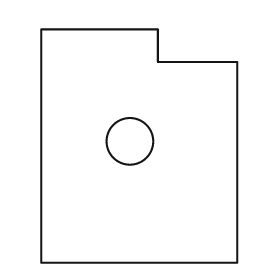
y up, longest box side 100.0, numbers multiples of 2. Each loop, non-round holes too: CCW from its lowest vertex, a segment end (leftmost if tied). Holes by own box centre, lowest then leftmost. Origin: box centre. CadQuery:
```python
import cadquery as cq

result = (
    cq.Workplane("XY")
    .moveTo(-42.0, -50.0)
    .lineTo(42.0, -50.0)
    .lineTo(42.0, 36.0)
    .lineTo(8.0, 36.0)
    .lineTo(8.0, 50.0)
    .lineTo(-42.0, 50.0)
    .close()
    .moveTo(-4.0, 2.0)
    .circle(10.0)
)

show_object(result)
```